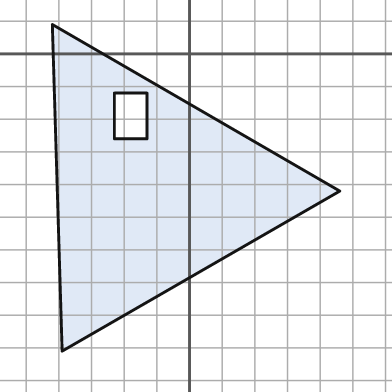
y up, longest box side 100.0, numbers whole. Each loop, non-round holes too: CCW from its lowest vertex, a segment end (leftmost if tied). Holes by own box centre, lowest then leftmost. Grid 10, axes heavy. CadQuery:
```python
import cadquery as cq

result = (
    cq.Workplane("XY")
    .moveTo(-39.0, -91.0)
    .lineTo(46.0, -42.0)
    .lineTo(-42.0, 9.0)
    .close()
    .moveTo(-23.0, -26.0)
    .lineTo(-13.0, -26.0)
    .lineTo(-13.0, -12.0)
    .lineTo(-23.0, -12.0)
    .close()
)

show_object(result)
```